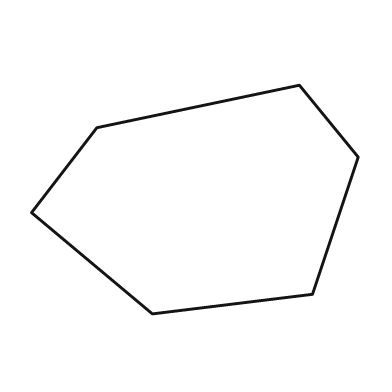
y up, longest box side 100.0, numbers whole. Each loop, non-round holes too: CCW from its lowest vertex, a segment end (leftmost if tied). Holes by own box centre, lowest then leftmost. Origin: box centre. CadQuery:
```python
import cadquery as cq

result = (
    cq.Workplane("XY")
    .moveTo(-13.0, -35.0)
    .lineTo(36.0, -29.0)
    .lineTo(50.0, 13.0)
    .lineTo(32.0, 35.0)
    .lineTo(-30.0, 22.0)
    .lineTo(-50.0, -4.0)
    .close()
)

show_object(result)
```